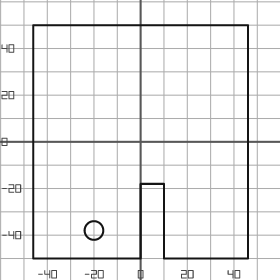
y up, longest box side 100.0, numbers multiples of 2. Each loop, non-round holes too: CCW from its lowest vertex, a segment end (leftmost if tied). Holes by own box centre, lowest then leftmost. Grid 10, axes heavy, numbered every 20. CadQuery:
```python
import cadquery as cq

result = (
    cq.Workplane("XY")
    .moveTo(-46.0, -50.0)
    .lineTo(0.0, -50.0)
    .lineTo(0.0, -18.0)
    .lineTo(10.0, -18.0)
    .lineTo(10.0, -50.0)
    .lineTo(46.0, -50.0)
    .lineTo(46.0, 50.0)
    .lineTo(-46.0, 50.0)
    .close()
    .moveTo(-20.0, -38.0)
    .circle(4.0)
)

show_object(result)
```